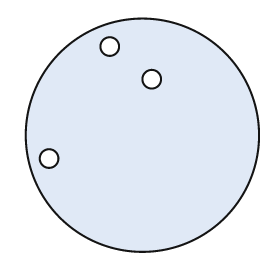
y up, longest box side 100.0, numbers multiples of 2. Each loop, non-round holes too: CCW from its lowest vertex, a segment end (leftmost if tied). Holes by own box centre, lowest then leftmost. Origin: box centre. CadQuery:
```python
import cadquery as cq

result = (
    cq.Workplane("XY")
    .moveTo(0.0, 0.0)
    .circle(50.0)
    .moveTo(-40.0, -10.0)
    .circle(4.0)
    .moveTo(4.0, 24.0)
    .circle(4.0)
    .moveTo(-14.0, 38.0)
    .circle(4.0)
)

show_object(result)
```